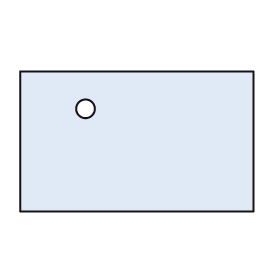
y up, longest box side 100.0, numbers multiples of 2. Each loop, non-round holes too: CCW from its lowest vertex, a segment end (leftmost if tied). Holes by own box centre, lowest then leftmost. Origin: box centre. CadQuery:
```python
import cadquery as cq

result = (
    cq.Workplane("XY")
    .moveTo(-50.0, -30.0)
    .lineTo(50.0, -30.0)
    .lineTo(50.0, 30.0)
    .lineTo(-50.0, 30.0)
    .close()
    .moveTo(-22.0, 14.0)
    .circle(4.0)
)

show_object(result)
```